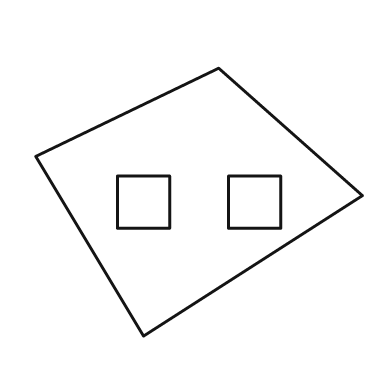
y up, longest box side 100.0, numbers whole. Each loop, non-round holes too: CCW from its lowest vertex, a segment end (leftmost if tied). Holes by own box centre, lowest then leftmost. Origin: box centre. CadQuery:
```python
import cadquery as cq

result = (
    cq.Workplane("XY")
    .moveTo(-17.0, -41.0)
    .lineTo(50.0, 2.0)
    .lineTo(6.0, 41.0)
    .lineTo(-50.0, 14.0)
    .close()
    .moveTo(-25.0, -8.0)
    .lineTo(-9.0, -8.0)
    .lineTo(-9.0, 8.0)
    .lineTo(-25.0, 8.0)
    .close()
    .moveTo(9.0, -8.0)
    .lineTo(25.0, -8.0)
    .lineTo(25.0, 8.0)
    .lineTo(9.0, 8.0)
    .close()
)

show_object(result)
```